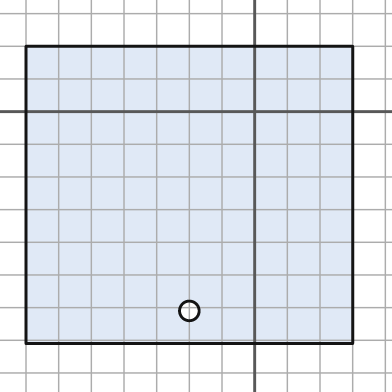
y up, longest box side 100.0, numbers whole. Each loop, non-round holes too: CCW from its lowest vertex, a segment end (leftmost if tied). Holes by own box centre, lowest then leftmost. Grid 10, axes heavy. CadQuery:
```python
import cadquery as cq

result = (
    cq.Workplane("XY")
    .moveTo(-70.0, -71.0)
    .lineTo(30.0, -71.0)
    .lineTo(30.0, 20.0)
    .lineTo(-70.0, 20.0)
    .close()
    .moveTo(-20.0, -61.0)
    .circle(3.0)
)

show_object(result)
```